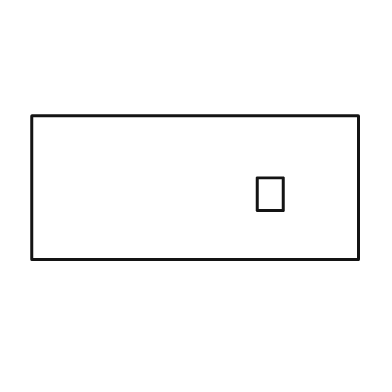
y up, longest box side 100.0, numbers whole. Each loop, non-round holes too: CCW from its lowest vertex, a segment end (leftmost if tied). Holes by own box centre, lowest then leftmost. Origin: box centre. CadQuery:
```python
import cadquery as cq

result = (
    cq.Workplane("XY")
    .moveTo(-50.0, -22.0)
    .lineTo(50.0, -22.0)
    .lineTo(50.0, 22.0)
    .lineTo(-50.0, 22.0)
    .close()
    .moveTo(19.0, -7.0)
    .lineTo(27.0, -7.0)
    .lineTo(27.0, 3.0)
    .lineTo(19.0, 3.0)
    .close()
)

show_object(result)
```